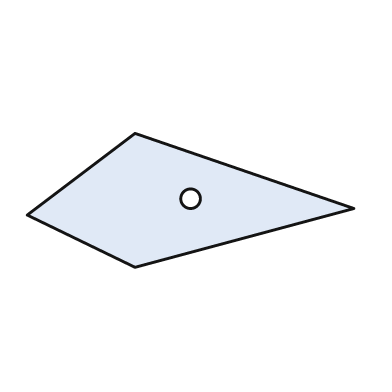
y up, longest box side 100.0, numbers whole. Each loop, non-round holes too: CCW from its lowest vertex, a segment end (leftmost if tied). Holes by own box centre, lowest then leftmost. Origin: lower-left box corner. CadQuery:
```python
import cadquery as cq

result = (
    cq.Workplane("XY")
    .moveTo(33.0, 0.0)
    .lineTo(100.0, 18.0)
    .lineTo(33.0, 41.0)
    .lineTo(0.0, 16.0)
    .close()
    .moveTo(50.0, 21.0)
    .circle(3.0)
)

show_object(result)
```